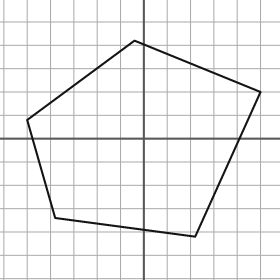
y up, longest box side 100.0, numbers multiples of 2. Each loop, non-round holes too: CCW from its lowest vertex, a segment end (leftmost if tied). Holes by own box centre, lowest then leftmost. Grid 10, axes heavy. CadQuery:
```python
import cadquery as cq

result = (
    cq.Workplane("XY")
    .moveTo(22.0, -42.0)
    .lineTo(50.0, 20.0)
    .lineTo(-4.0, 42.0)
    .lineTo(-50.0, 8.0)
    .lineTo(-38.0, -34.0)
    .close()
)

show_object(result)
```